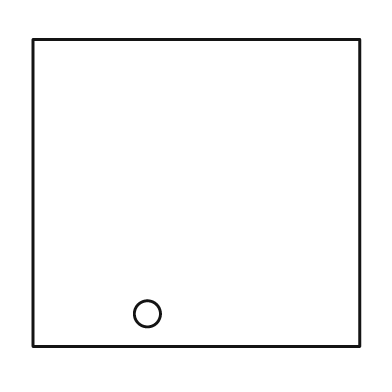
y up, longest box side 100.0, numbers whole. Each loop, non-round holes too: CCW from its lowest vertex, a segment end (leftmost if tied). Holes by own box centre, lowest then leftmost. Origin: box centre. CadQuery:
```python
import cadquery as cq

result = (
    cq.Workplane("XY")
    .moveTo(-50.0, -47.0)
    .lineTo(50.0, -47.0)
    .lineTo(50.0, 47.0)
    .lineTo(-50.0, 47.0)
    .close()
    .moveTo(-15.0, -37.0)
    .circle(4.0)
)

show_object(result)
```